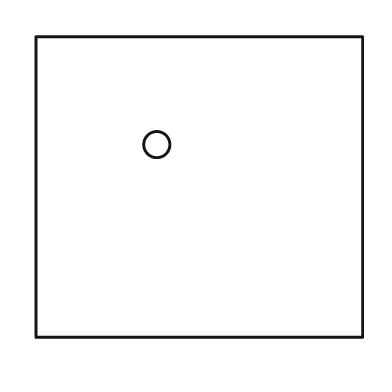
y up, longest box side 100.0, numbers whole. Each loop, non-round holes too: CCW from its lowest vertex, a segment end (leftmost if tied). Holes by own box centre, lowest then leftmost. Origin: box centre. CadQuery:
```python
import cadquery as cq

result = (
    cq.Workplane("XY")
    .moveTo(-50.0, -46.0)
    .lineTo(50.0, -46.0)
    .lineTo(50.0, 46.0)
    .lineTo(-50.0, 46.0)
    .close()
    .moveTo(-13.0, 13.0)
    .circle(4.0)
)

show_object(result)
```